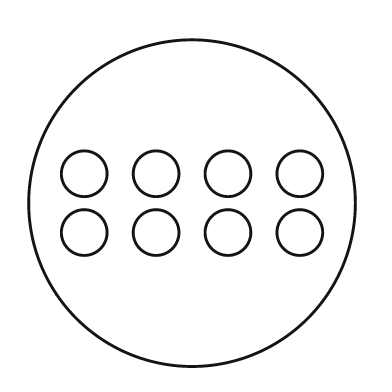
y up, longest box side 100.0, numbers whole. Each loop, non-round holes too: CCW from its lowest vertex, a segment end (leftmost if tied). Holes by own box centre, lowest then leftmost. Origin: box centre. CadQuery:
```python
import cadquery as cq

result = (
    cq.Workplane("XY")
    .moveTo(0.0, 0.0)
    .circle(50.0)
    .moveTo(-33.0, -9.0)
    .circle(7.0)
    .moveTo(-11.0, -9.0)
    .circle(7.0)
    .moveTo(11.0, -9.0)
    .circle(7.0)
    .moveTo(33.0, -9.0)
    .circle(7.0)
    .moveTo(-33.0, 9.0)
    .circle(7.0)
    .moveTo(-11.0, 9.0)
    .circle(7.0)
    .moveTo(11.0, 9.0)
    .circle(7.0)
    .moveTo(33.0, 9.0)
    .circle(7.0)
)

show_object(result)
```